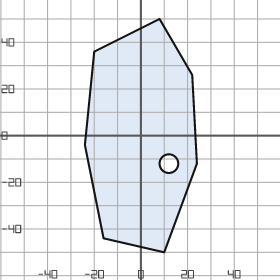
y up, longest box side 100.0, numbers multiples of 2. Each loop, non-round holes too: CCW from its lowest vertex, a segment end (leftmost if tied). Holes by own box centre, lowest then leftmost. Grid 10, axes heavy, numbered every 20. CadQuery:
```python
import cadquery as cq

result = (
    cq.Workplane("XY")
    .moveTo(10.0, -50.0)
    .lineTo(24.0, -12.0)
    .lineTo(22.0, 26.0)
    .lineTo(8.0, 50.0)
    .lineTo(-20.0, 36.0)
    .lineTo(-24.0, -4.0)
    .lineTo(-16.0, -44.0)
    .close()
    .moveTo(12.0, -12.0)
    .circle(4.0)
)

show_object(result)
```